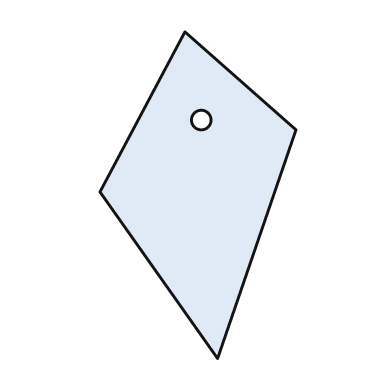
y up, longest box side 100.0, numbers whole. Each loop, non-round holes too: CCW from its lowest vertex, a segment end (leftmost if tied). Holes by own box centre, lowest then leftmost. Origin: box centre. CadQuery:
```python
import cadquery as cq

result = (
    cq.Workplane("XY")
    .moveTo(6.0, -50.0)
    .lineTo(30.0, 20.0)
    .lineTo(-4.0, 50.0)
    .lineTo(-30.0, 1.0)
    .close()
    .moveTo(1.0, 23.0)
    .circle(3.0)
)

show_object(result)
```